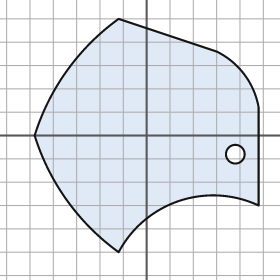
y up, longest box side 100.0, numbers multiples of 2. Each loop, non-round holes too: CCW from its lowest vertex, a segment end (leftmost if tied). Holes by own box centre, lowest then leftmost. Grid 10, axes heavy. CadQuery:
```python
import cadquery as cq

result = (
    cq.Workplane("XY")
    .moveTo(-12.0, -50.0)
    .threePointArc((14.0, -28.0), (48.0, -30.0))
    .lineTo(48.0, 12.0)
    .threePointArc((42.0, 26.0), (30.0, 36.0))
    .lineTo(-12.0, 50.0)
    .threePointArc((-34.0, 28.0), (-48.0, 0.0))
    .threePointArc((-34.0, -28.0), (-12.0, -50.0))
    .close()
    .moveTo(38.0, -8.0)
    .circle(4.0)
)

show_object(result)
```